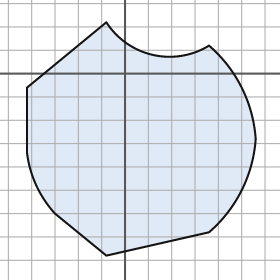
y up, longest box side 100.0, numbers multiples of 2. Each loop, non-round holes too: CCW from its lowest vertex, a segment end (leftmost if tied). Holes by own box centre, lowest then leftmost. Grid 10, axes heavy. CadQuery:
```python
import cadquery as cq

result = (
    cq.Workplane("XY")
    .moveTo(-8.0, -78.0)
    .lineTo(36.0, -68.0)
    .threePointArc((50.0, -50.0), (56.0, -28.0))
    .threePointArc((50.0, -6.0), (36.0, 12.0))
    .threePointArc((12.0, 8.0), (-8.0, 22.0))
    .lineTo(-42.0, -6.0)
    .lineTo(-42.0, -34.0)
    .threePointArc((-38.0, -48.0), (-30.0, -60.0))
    .close()
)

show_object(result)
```